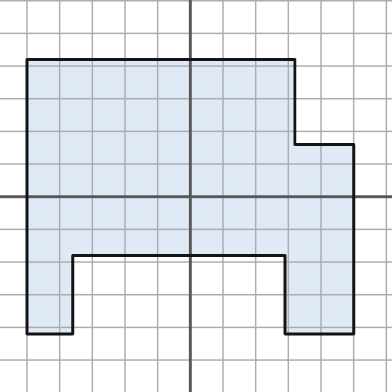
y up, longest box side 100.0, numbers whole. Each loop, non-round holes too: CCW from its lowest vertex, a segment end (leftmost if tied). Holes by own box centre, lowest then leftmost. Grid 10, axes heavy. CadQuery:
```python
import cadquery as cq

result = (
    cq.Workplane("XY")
    .moveTo(-50.0, -42.0)
    .lineTo(-36.0, -42.0)
    .lineTo(-36.0, -18.0)
    .lineTo(29.0, -18.0)
    .lineTo(29.0, -42.0)
    .lineTo(50.0, -42.0)
    .lineTo(50.0, 16.0)
    .lineTo(32.0, 16.0)
    .lineTo(32.0, 42.0)
    .lineTo(-50.0, 42.0)
    .close()
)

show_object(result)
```